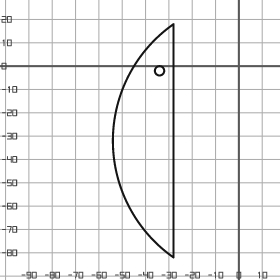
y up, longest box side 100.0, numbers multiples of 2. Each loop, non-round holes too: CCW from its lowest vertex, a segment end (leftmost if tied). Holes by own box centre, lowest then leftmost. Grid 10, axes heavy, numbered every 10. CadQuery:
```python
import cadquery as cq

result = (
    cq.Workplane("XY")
    .moveTo(-28.0, -82.0)
    .lineTo(-28.0, 18.0)
    .threePointArc((-54.0, -32.0), (-28.0, -82.0))
    .close()
    .moveTo(-34.0, -2.0)
    .circle(2.0)
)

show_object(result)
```